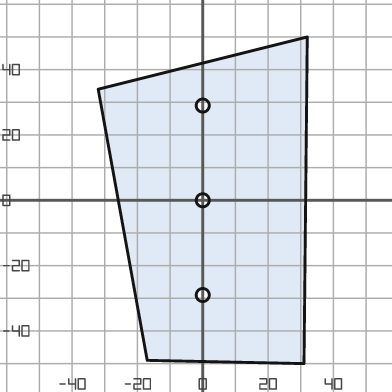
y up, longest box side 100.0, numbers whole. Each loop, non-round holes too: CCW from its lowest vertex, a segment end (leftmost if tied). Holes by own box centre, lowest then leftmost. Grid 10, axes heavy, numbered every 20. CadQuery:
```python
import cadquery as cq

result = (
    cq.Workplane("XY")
    .moveTo(31.0, -50.0)
    .lineTo(32.0, 50.0)
    .lineTo(-32.0, 34.0)
    .lineTo(-17.0, -49.0)
    .close()
    .moveTo(0.0, -29.0)
    .circle(2.0)
    .moveTo(0.0, 0.0)
    .circle(2.0)
    .moveTo(0.0, 29.0)
    .circle(2.0)
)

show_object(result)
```